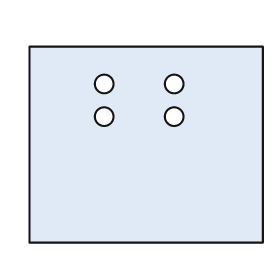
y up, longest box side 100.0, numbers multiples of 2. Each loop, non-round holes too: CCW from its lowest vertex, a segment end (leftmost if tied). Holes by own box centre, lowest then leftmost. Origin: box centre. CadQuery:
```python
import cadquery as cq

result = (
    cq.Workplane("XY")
    .moveTo(-50.0, -42.0)
    .lineTo(50.0, -42.0)
    .lineTo(50.0, 42.0)
    .lineTo(-50.0, 42.0)
    .close()
    .moveTo(-18.0, 12.0)
    .circle(4.0)
    .moveTo(12.0, 12.0)
    .circle(4.0)
    .moveTo(-18.0, 26.0)
    .circle(4.0)
    .moveTo(12.0, 26.0)
    .circle(4.0)
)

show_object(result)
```